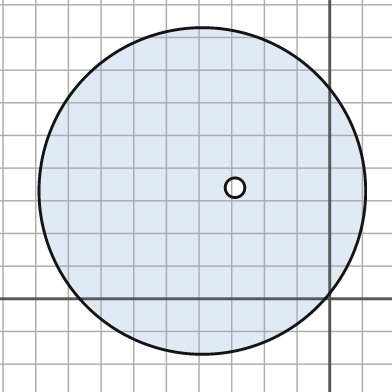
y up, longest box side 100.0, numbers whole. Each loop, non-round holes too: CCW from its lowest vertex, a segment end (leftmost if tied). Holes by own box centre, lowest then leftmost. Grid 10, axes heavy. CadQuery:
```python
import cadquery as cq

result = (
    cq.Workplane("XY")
    .moveTo(-39.0, 33.0)
    .circle(50.0)
    .moveTo(-29.0, 34.0)
    .circle(3.0)
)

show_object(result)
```